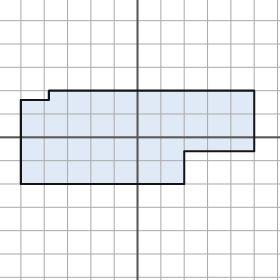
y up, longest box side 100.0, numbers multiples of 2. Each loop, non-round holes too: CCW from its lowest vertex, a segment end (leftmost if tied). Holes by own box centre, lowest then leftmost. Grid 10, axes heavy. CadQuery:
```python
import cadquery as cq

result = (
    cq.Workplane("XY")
    .moveTo(-50.0, -20.0)
    .lineTo(20.0, -20.0)
    .lineTo(20.0, -6.0)
    .lineTo(50.0, -6.0)
    .lineTo(50.0, 20.0)
    .lineTo(-38.0, 20.0)
    .lineTo(-38.0, 16.0)
    .lineTo(-50.0, 16.0)
    .close()
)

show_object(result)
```